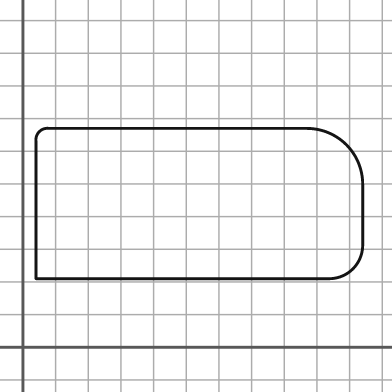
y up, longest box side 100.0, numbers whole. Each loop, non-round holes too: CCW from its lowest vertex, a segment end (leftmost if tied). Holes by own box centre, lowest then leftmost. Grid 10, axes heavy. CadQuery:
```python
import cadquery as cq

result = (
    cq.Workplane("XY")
    .moveTo(4.0, 21.0)
    .lineTo(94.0, 21.0)
    .threePointArc((101.0, 24.0), (104.0, 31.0))
    .lineTo(104.0, 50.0)
    .threePointArc((99.0, 62.0), (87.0, 67.0))
    .lineTo(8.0, 67.0)
    .threePointArc((5.0, 66.0), (4.0, 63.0))
    .close()
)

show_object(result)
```